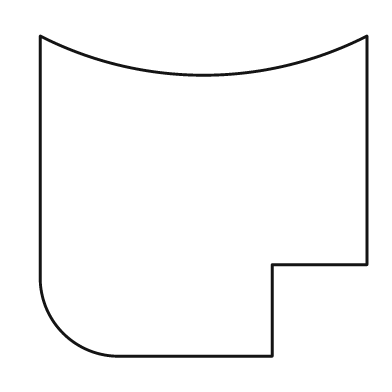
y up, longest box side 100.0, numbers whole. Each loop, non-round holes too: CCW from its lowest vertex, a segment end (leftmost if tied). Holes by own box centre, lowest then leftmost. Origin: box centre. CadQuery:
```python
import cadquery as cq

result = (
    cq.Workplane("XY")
    .moveTo(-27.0, -49.0)
    .lineTo(21.0, -49.0)
    .lineTo(21.0, -21.0)
    .lineTo(50.0, -21.0)
    .lineTo(50.0, 49.0)
    .threePointArc((0.0, 37.0), (-50.0, 49.0))
    .lineTo(-50.0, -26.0)
    .threePointArc((-43.0, -42.0), (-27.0, -49.0))
    .close()
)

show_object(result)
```